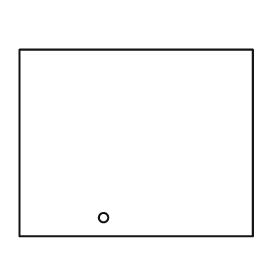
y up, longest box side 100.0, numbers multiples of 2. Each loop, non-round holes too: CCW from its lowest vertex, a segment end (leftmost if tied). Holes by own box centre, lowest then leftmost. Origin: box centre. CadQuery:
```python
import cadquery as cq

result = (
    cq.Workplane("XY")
    .moveTo(-50.0, -40.0)
    .lineTo(50.0, -40.0)
    .lineTo(50.0, 40.0)
    .lineTo(-50.0, 40.0)
    .close()
    .moveTo(-14.0, -32.0)
    .circle(2.0)
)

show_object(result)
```